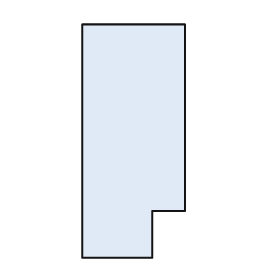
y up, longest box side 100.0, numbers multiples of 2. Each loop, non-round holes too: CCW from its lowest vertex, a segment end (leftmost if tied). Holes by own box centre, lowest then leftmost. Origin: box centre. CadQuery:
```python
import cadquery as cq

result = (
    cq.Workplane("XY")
    .moveTo(-22.0, -50.0)
    .lineTo(8.0, -50.0)
    .lineTo(8.0, -30.0)
    .lineTo(22.0, -30.0)
    .lineTo(22.0, 50.0)
    .lineTo(-22.0, 50.0)
    .close()
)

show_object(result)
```